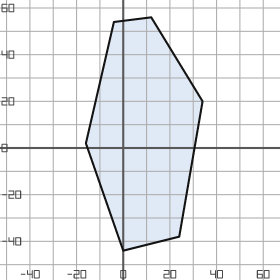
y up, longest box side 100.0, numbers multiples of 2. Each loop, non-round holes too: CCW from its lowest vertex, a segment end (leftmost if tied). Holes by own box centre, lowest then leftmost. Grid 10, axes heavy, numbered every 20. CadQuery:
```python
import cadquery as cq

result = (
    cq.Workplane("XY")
    .moveTo(0.0, -44.0)
    .lineTo(24.0, -38.0)
    .lineTo(34.0, 20.0)
    .lineTo(12.0, 56.0)
    .lineTo(-4.0, 54.0)
    .lineTo(-16.0, 2.0)
    .close()
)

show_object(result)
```